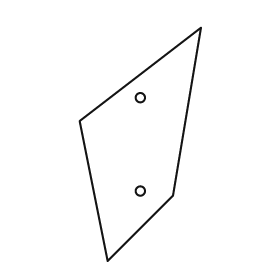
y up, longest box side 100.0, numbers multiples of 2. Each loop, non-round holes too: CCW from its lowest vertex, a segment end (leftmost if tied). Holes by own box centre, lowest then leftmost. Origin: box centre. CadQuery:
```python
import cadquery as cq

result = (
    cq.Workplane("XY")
    .moveTo(-14.0, -50.0)
    .lineTo(14.0, -22.0)
    .lineTo(26.0, 50.0)
    .lineTo(-26.0, 10.0)
    .close()
    .moveTo(0.0, -20.0)
    .circle(2.0)
    .moveTo(0.0, 20.0)
    .circle(2.0)
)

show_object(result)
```